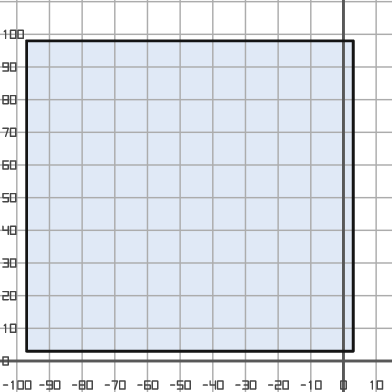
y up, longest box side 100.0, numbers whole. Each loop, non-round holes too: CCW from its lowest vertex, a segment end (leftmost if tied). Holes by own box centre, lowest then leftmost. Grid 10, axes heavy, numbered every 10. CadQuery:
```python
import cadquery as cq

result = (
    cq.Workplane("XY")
    .moveTo(-97.0, 3.0)
    .lineTo(3.0, 3.0)
    .lineTo(3.0, 98.0)
    .lineTo(-97.0, 98.0)
    .close()
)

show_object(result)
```